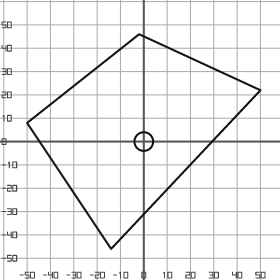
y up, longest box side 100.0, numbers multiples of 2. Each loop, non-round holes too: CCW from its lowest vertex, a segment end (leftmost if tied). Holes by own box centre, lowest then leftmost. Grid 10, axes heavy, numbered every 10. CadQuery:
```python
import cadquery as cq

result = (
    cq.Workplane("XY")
    .moveTo(-14.0, -46.0)
    .lineTo(50.0, 22.0)
    .lineTo(-2.0, 46.0)
    .lineTo(-50.0, 8.0)
    .close()
    .moveTo(0.0, 0.0)
    .circle(4.0)
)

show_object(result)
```